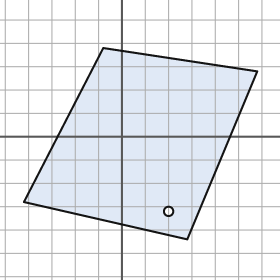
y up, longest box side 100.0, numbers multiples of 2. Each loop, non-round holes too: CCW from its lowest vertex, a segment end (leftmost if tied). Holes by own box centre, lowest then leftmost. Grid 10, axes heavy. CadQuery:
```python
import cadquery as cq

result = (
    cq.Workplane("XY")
    .moveTo(28.0, -44.0)
    .lineTo(58.0, 28.0)
    .lineTo(-8.0, 38.0)
    .lineTo(-42.0, -28.0)
    .close()
    .moveTo(20.0, -32.0)
    .circle(2.0)
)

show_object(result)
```